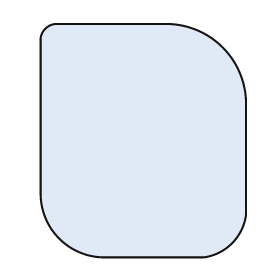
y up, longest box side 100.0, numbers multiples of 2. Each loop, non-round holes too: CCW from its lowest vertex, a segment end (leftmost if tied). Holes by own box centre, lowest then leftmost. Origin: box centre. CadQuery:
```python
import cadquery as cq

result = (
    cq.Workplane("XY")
    .moveTo(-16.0, -50.0)
    .lineTo(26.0, -50.0)
    .threePointArc((38.0, -44.0), (44.0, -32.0))
    .lineTo(44.0, 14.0)
    .threePointArc((34.0, 40.0), (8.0, 50.0))
    .lineTo(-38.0, 50.0)
    .threePointArc((-42.0, 48.0), (-44.0, 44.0))
    .lineTo(-44.0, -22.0)
    .threePointArc((-36.0, -42.0), (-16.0, -50.0))
    .close()
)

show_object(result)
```